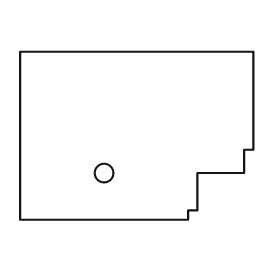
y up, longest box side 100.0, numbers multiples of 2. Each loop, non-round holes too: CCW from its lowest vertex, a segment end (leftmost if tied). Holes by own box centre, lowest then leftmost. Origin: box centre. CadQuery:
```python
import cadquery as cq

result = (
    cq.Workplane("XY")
    .moveTo(-50.0, -36.0)
    .lineTo(22.0, -36.0)
    .lineTo(22.0, -32.0)
    .lineTo(26.0, -32.0)
    .lineTo(26.0, -16.0)
    .lineTo(46.0, -16.0)
    .lineTo(46.0, -6.0)
    .lineTo(50.0, -6.0)
    .lineTo(50.0, 36.0)
    .lineTo(-50.0, 36.0)
    .close()
    .moveTo(-14.0, -16.0)
    .circle(4.0)
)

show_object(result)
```